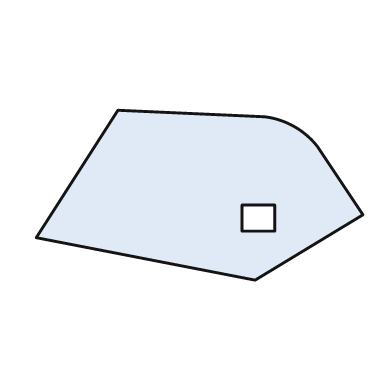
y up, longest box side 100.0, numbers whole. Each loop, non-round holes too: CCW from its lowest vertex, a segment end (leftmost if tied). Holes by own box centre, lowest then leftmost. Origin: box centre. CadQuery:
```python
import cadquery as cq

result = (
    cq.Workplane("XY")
    .moveTo(17.0, -26.0)
    .lineTo(50.0, -6.0)
    .lineTo(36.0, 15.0)
    .threePointArc((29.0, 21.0), (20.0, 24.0))
    .lineTo(-25.0, 26.0)
    .lineTo(-50.0, -13.0)
    .close()
    .moveTo(13.0, -11.0)
    .lineTo(23.0, -11.0)
    .lineTo(23.0, -3.0)
    .lineTo(13.0, -3.0)
    .close()
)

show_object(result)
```